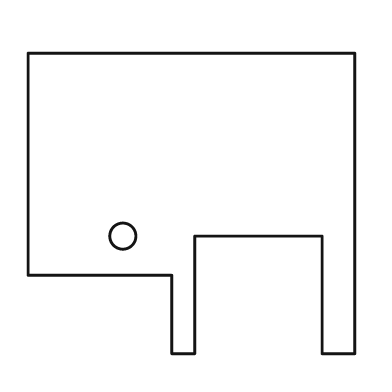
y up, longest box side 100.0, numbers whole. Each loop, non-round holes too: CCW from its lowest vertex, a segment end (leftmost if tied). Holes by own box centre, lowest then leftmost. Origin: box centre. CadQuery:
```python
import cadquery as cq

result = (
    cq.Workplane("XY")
    .moveTo(-6.0, -46.0)
    .lineTo(1.0, -46.0)
    .lineTo(1.0, -10.0)
    .lineTo(40.0, -10.0)
    .lineTo(40.0, -46.0)
    .lineTo(50.0, -46.0)
    .lineTo(50.0, 46.0)
    .lineTo(-50.0, 46.0)
    .lineTo(-50.0, -22.0)
    .lineTo(-6.0, -22.0)
    .close()
    .moveTo(-21.0, -10.0)
    .circle(4.0)
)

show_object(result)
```